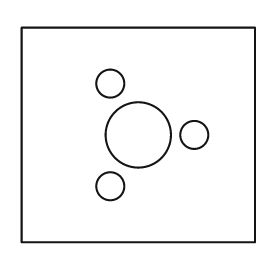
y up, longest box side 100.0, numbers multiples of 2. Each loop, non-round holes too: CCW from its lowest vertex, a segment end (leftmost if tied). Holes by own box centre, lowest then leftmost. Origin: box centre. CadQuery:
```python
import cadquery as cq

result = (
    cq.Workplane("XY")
    .moveTo(-50.0, -46.0)
    .lineTo(50.0, -46.0)
    .lineTo(50.0, 46.0)
    .lineTo(-50.0, 46.0)
    .close()
    .moveTo(-12.0, -22.0)
    .circle(6.0)
    .moveTo(0.0, 0.0)
    .circle(14.0)
    .moveTo(24.0, 0.0)
    .circle(6.0)
    .moveTo(-12.0, 22.0)
    .circle(6.0)
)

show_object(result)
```